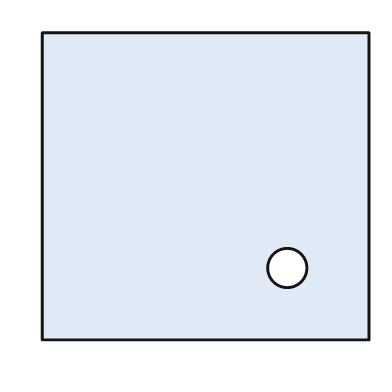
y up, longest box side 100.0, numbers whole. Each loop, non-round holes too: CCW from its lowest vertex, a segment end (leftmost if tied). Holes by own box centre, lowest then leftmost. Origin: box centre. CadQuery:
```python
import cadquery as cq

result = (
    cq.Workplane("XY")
    .moveTo(-50.0, -47.0)
    .lineTo(50.0, -47.0)
    .lineTo(50.0, 47.0)
    .lineTo(-50.0, 47.0)
    .close()
    .moveTo(25.0, -25.0)
    .circle(6.0)
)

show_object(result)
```